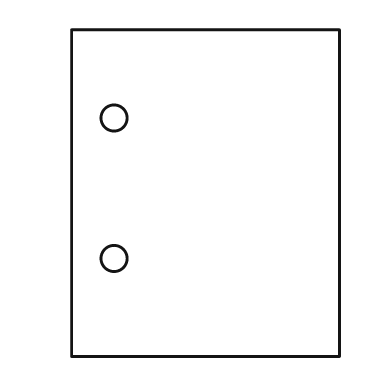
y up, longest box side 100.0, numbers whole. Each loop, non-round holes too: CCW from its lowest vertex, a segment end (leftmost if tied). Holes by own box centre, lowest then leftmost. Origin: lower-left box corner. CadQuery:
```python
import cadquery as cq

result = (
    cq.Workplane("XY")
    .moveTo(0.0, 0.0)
    .lineTo(82.0, 0.0)
    .lineTo(82.0, 100.0)
    .lineTo(0.0, 100.0)
    .close()
    .moveTo(13.0, 30.0)
    .circle(4.0)
    .moveTo(13.0, 73.0)
    .circle(4.0)
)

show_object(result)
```